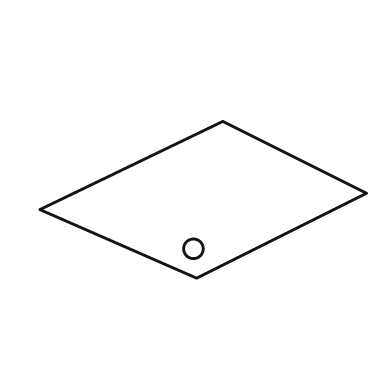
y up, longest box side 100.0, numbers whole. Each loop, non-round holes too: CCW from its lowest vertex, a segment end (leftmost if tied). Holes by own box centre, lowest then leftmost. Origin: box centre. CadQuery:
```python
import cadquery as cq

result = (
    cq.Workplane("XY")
    .moveTo(-2.0, -24.0)
    .lineTo(50.0, 2.0)
    .lineTo(6.0, 24.0)
    .lineTo(-50.0, -3.0)
    .close()
    .moveTo(-3.0, -15.0)
    .circle(3.0)
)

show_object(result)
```